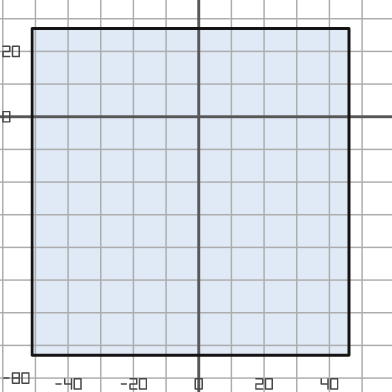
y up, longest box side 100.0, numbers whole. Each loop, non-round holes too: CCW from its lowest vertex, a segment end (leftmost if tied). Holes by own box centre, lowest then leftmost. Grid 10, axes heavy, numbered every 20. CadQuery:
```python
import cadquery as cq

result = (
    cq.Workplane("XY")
    .moveTo(-51.0, -73.0)
    .lineTo(46.0, -73.0)
    .lineTo(46.0, 27.0)
    .lineTo(-51.0, 27.0)
    .close()
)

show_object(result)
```